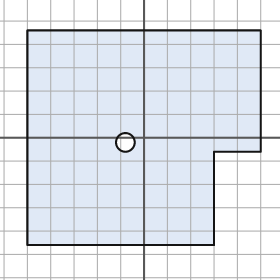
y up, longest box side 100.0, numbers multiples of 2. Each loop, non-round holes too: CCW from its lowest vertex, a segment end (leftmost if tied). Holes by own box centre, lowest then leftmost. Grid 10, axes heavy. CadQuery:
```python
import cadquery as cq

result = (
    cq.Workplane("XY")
    .moveTo(-50.0, -46.0)
    .lineTo(30.0, -46.0)
    .lineTo(30.0, -6.0)
    .lineTo(50.0, -6.0)
    .lineTo(50.0, 46.0)
    .lineTo(-50.0, 46.0)
    .close()
    .moveTo(-8.0, -2.0)
    .circle(4.0)
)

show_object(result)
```